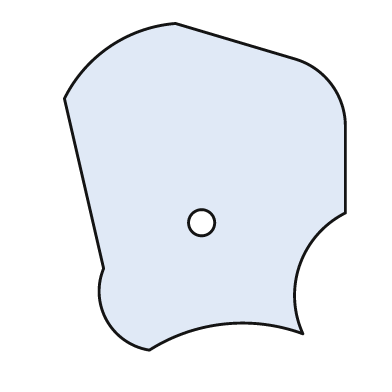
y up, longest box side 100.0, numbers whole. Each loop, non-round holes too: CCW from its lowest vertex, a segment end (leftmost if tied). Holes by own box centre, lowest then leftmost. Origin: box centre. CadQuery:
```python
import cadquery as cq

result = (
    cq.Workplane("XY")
    .moveTo(-17.0, -50.0)
    .threePointArc((6.0, -42.0), (30.0, -45.0))
    .threePointArc((29.0, -24.0), (43.0, -8.0))
    .lineTo(43.0, 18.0)
    .threePointArc((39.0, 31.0), (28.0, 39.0))
    .lineTo(-9.0, 50.0)
    .threePointArc((-29.0, 43.0), (-43.0, 27.0))
    .lineTo(-31.0, -25.0)
    .threePointArc((-30.0, -41.0), (-17.0, -50.0))
    .close()
    .moveTo(-1.0, -11.0)
    .circle(4.0)
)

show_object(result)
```